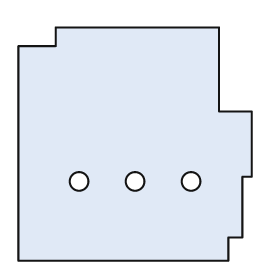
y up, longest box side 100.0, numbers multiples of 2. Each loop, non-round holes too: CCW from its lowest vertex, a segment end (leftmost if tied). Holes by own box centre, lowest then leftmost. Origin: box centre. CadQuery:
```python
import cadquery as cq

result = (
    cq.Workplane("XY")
    .moveTo(-50.0, -50.0)
    .lineTo(40.0, -50.0)
    .lineTo(40.0, -40.0)
    .lineTo(46.0, -40.0)
    .lineTo(46.0, -14.0)
    .lineTo(50.0, -14.0)
    .lineTo(50.0, 14.0)
    .lineTo(36.0, 14.0)
    .lineTo(36.0, 50.0)
    .lineTo(-34.0, 50.0)
    .lineTo(-34.0, 42.0)
    .lineTo(-50.0, 42.0)
    .close()
    .moveTo(-24.0, -16.0)
    .circle(4.0)
    .moveTo(0.0, -16.0)
    .circle(4.0)
    .moveTo(24.0, -16.0)
    .circle(4.0)
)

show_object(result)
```